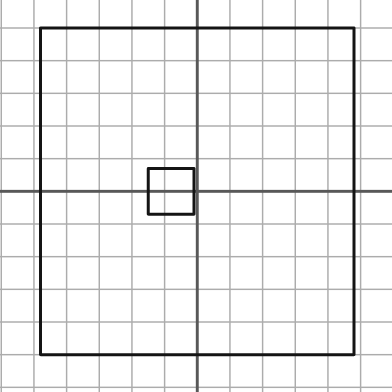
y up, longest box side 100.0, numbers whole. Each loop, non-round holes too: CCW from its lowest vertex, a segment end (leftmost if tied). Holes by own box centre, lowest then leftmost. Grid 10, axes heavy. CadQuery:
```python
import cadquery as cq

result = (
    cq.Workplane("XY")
    .moveTo(-48.0, -50.0)
    .lineTo(48.0, -50.0)
    .lineTo(48.0, 50.0)
    .lineTo(-48.0, 50.0)
    .close()
    .moveTo(-15.0, -7.0)
    .lineTo(-1.0, -7.0)
    .lineTo(-1.0, 7.0)
    .lineTo(-15.0, 7.0)
    .close()
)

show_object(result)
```